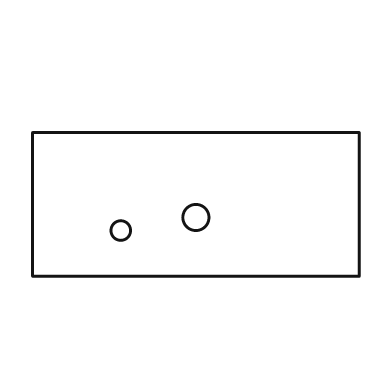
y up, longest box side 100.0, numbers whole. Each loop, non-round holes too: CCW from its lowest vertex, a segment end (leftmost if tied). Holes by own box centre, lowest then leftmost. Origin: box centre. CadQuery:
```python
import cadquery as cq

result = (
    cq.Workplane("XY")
    .moveTo(-50.0, -22.0)
    .lineTo(50.0, -22.0)
    .lineTo(50.0, 22.0)
    .lineTo(-50.0, 22.0)
    .close()
    .moveTo(-23.0, -8.0)
    .circle(3.0)
    .moveTo(0.0, -4.0)
    .circle(4.0)
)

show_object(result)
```